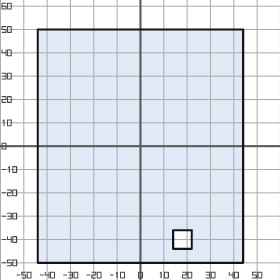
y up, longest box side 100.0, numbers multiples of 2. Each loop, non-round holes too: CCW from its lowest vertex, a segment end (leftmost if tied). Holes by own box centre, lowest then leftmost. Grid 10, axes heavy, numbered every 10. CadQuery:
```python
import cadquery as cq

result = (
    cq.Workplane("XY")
    .moveTo(-44.0, -50.0)
    .lineTo(44.0, -50.0)
    .lineTo(44.0, 50.0)
    .lineTo(-44.0, 50.0)
    .close()
    .moveTo(14.0, -44.0)
    .lineTo(22.0, -44.0)
    .lineTo(22.0, -36.0)
    .lineTo(14.0, -36.0)
    .close()
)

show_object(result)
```